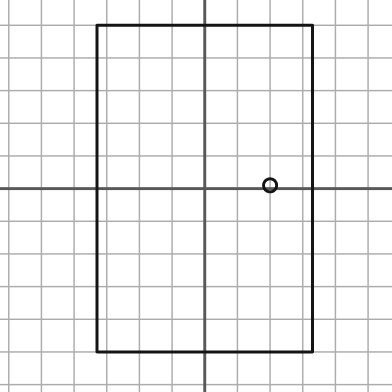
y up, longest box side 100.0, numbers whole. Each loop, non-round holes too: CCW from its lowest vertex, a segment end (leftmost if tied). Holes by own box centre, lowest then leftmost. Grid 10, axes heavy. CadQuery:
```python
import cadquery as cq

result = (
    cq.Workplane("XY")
    .moveTo(-33.0, -50.0)
    .lineTo(33.0, -50.0)
    .lineTo(33.0, 50.0)
    .lineTo(-33.0, 50.0)
    .close()
    .moveTo(20.0, 1.0)
    .circle(2.0)
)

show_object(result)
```